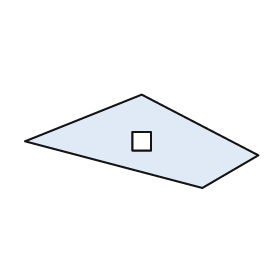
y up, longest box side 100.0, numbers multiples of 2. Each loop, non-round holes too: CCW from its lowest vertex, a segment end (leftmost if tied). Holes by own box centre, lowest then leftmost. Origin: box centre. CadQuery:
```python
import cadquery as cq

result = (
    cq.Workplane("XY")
    .moveTo(26.0, -20.0)
    .lineTo(50.0, -6.0)
    .lineTo(0.0, 20.0)
    .lineTo(-50.0, 0.0)
    .close()
    .moveTo(-4.0, -4.0)
    .lineTo(4.0, -4.0)
    .lineTo(4.0, 4.0)
    .lineTo(-4.0, 4.0)
    .close()
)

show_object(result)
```